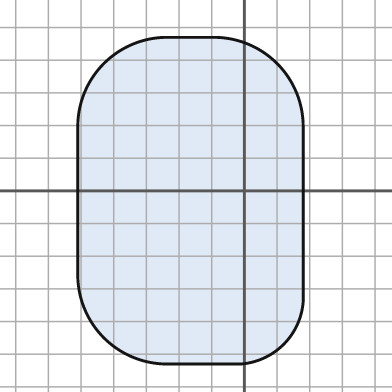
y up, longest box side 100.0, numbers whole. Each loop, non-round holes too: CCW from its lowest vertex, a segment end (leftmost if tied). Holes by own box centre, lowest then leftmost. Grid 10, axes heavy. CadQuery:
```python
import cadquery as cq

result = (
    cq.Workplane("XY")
    .moveTo(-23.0, -53.0)
    .lineTo(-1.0, -53.0)
    .threePointArc((12.0, -47.0), (18.0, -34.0))
    .lineTo(18.0, 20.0)
    .threePointArc((10.0, 39.0), (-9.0, 47.0))
    .lineTo(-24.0, 47.0)
    .threePointArc((-43.0, 39.0), (-51.0, 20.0))
    .lineTo(-51.0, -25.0)
    .threePointArc((-43.0, -45.0), (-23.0, -53.0))
    .close()
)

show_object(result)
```